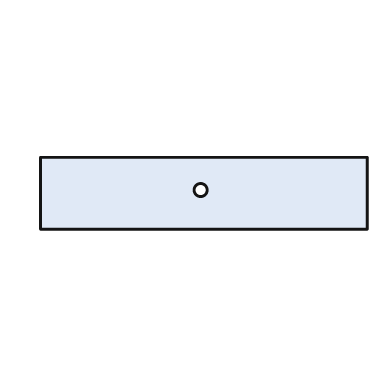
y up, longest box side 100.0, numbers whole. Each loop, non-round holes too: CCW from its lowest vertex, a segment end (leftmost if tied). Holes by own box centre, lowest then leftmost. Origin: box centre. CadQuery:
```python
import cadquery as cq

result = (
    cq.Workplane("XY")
    .moveTo(-50.0, -11.0)
    .lineTo(50.0, -11.0)
    .lineTo(50.0, 11.0)
    .lineTo(-50.0, 11.0)
    .close()
    .moveTo(-1.0, 1.0)
    .circle(2.0)
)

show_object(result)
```